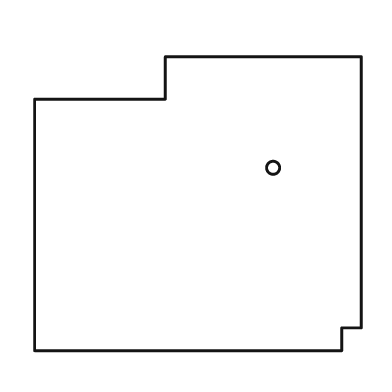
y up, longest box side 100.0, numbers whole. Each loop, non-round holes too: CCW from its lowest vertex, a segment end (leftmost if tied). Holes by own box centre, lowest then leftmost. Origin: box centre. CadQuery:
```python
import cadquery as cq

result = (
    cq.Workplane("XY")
    .moveTo(-50.0, -45.0)
    .lineTo(44.0, -45.0)
    .lineTo(44.0, -38.0)
    .lineTo(50.0, -38.0)
    .lineTo(50.0, 45.0)
    .lineTo(-10.0, 45.0)
    .lineTo(-10.0, 32.0)
    .lineTo(-50.0, 32.0)
    .close()
    .moveTo(23.0, 11.0)
    .circle(2.0)
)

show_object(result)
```